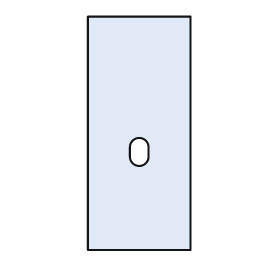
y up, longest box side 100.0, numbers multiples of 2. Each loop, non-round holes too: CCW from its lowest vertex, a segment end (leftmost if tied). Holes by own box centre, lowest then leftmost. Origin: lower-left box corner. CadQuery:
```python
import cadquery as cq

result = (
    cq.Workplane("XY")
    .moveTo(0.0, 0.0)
    .lineTo(44.0, 0.0)
    .lineTo(44.0, 100.0)
    .lineTo(0.0, 100.0)
    .close()
    .moveTo(18.0, 40.0)
    .threePointArc((22.0, 36.0), (26.0, 40.0))
    .lineTo(26.0, 44.0)
    .threePointArc((22.0, 48.0), (18.0, 44.0))
    .close()
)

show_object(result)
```